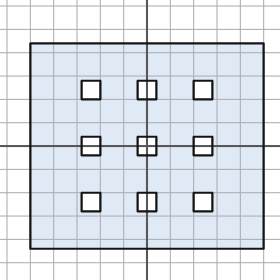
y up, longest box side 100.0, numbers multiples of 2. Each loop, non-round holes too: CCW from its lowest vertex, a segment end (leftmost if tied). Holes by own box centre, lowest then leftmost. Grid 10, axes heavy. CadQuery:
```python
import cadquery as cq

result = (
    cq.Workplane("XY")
    .moveTo(-50.0, -44.0)
    .lineTo(50.0, -44.0)
    .lineTo(50.0, 44.0)
    .lineTo(-50.0, 44.0)
    .close()
    .moveTo(-28.0, -28.0)
    .lineTo(-20.0, -28.0)
    .lineTo(-20.0, -20.0)
    .lineTo(-28.0, -20.0)
    .close()
    .moveTo(-4.0, -28.0)
    .lineTo(4.0, -28.0)
    .lineTo(4.0, -20.0)
    .lineTo(-4.0, -20.0)
    .close()
    .moveTo(20.0, -28.0)
    .lineTo(28.0, -28.0)
    .lineTo(28.0, -20.0)
    .lineTo(20.0, -20.0)
    .close()
    .moveTo(-28.0, -4.0)
    .lineTo(-20.0, -4.0)
    .lineTo(-20.0, 4.0)
    .lineTo(-28.0, 4.0)
    .close()
    .moveTo(-4.0, -4.0)
    .lineTo(4.0, -4.0)
    .lineTo(4.0, 4.0)
    .lineTo(-4.0, 4.0)
    .close()
    .moveTo(20.0, -4.0)
    .lineTo(28.0, -4.0)
    .lineTo(28.0, 4.0)
    .lineTo(20.0, 4.0)
    .close()
    .moveTo(-28.0, 20.0)
    .lineTo(-20.0, 20.0)
    .lineTo(-20.0, 28.0)
    .lineTo(-28.0, 28.0)
    .close()
    .moveTo(-4.0, 20.0)
    .lineTo(4.0, 20.0)
    .lineTo(4.0, 28.0)
    .lineTo(-4.0, 28.0)
    .close()
    .moveTo(20.0, 20.0)
    .lineTo(28.0, 20.0)
    .lineTo(28.0, 28.0)
    .lineTo(20.0, 28.0)
    .close()
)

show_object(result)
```